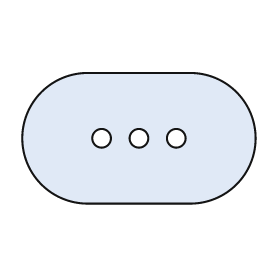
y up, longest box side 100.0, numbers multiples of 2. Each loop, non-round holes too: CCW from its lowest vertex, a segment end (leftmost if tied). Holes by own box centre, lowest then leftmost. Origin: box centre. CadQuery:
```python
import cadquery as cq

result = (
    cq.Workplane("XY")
    .moveTo(-22.0, -28.0)
    .lineTo(22.0, -28.0)
    .threePointArc((50.0, 0.0), (22.0, 28.0))
    .lineTo(-22.0, 28.0)
    .threePointArc((-50.0, 0.0), (-22.0, -28.0))
    .close()
    .moveTo(-16.0, 0.0)
    .circle(4.0)
    .moveTo(0.0, 0.0)
    .circle(4.0)
    .moveTo(16.0, 0.0)
    .circle(4.0)
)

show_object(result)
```